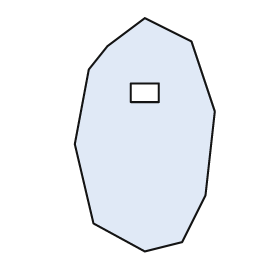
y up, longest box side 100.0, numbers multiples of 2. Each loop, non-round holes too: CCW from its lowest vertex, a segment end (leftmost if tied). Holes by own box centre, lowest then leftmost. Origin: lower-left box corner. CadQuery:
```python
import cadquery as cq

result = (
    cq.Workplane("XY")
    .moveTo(30.0, 0.0)
    .lineTo(46.0, 4.0)
    .lineTo(56.0, 24.0)
    .lineTo(60.0, 60.0)
    .lineTo(50.0, 90.0)
    .lineTo(30.0, 100.0)
    .lineTo(14.0, 88.0)
    .lineTo(6.0, 78.0)
    .lineTo(0.0, 46.0)
    .lineTo(8.0, 12.0)
    .close()
    .moveTo(24.0, 64.0)
    .lineTo(36.0, 64.0)
    .lineTo(36.0, 72.0)
    .lineTo(24.0, 72.0)
    .close()
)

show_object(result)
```